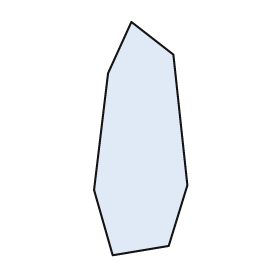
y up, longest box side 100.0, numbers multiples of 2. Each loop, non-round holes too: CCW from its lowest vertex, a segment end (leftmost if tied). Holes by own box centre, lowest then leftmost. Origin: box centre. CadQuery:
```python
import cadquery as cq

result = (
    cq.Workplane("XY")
    .moveTo(-12.0, -50.0)
    .lineTo(12.0, -46.0)
    .lineTo(20.0, -20.0)
    .lineTo(14.0, 36.0)
    .lineTo(-4.0, 50.0)
    .lineTo(-14.0, 28.0)
    .lineTo(-20.0, -22.0)
    .close()
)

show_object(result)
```